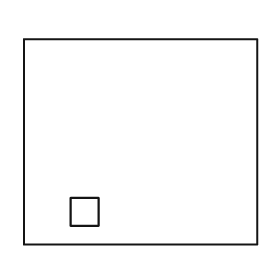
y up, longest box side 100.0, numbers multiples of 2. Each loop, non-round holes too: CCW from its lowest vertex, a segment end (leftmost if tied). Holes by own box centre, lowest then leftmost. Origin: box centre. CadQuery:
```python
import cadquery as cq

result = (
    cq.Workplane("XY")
    .moveTo(-50.0, -44.0)
    .lineTo(50.0, -44.0)
    .lineTo(50.0, 44.0)
    .lineTo(-50.0, 44.0)
    .close()
    .moveTo(-30.0, -36.0)
    .lineTo(-18.0, -36.0)
    .lineTo(-18.0, -24.0)
    .lineTo(-30.0, -24.0)
    .close()
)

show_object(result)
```